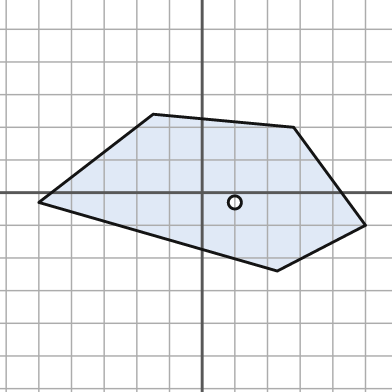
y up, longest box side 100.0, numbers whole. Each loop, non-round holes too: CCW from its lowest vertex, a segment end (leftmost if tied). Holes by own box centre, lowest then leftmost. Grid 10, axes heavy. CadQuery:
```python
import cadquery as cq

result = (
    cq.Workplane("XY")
    .moveTo(23.0, -24.0)
    .lineTo(50.0, -10.0)
    .lineTo(28.0, 20.0)
    .lineTo(-15.0, 24.0)
    .lineTo(-50.0, -3.0)
    .close()
    .moveTo(10.0, -3.0)
    .circle(2.0)
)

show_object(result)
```